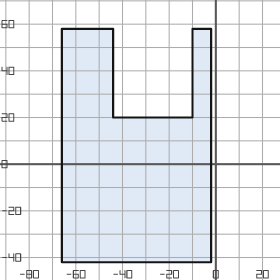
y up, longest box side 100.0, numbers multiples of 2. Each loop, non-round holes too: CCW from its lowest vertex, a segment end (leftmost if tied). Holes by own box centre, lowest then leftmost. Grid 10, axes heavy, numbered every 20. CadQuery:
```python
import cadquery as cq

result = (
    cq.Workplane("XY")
    .moveTo(-66.0, -42.0)
    .lineTo(-2.0, -42.0)
    .lineTo(-2.0, 58.0)
    .lineTo(-10.0, 58.0)
    .lineTo(-10.0, 20.0)
    .lineTo(-44.0, 20.0)
    .lineTo(-44.0, 58.0)
    .lineTo(-66.0, 58.0)
    .close()
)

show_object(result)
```